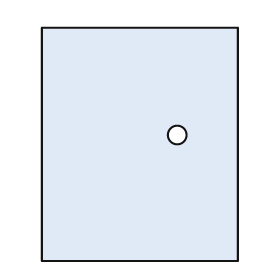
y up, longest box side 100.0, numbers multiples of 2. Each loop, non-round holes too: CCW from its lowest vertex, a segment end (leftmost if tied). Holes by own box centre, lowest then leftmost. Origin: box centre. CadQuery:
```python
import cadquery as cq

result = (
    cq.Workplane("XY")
    .moveTo(-42.0, -50.0)
    .lineTo(42.0, -50.0)
    .lineTo(42.0, 50.0)
    .lineTo(-42.0, 50.0)
    .close()
    .moveTo(16.0, 4.0)
    .circle(4.0)
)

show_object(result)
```